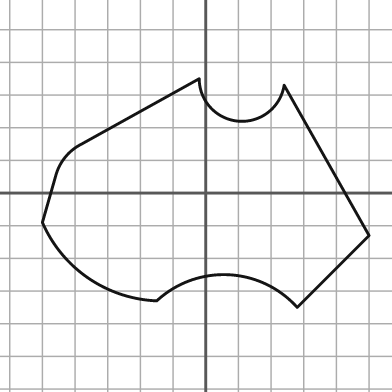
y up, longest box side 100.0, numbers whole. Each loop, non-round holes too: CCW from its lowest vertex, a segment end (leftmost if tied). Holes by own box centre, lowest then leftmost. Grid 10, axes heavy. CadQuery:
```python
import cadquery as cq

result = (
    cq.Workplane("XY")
    .moveTo(28.0, -35.0)
    .lineTo(50.0, -13.0)
    .lineTo(24.0, 33.0)
    .threePointArc((10.0, 22.0), (-2.0, 35.0))
    .lineTo(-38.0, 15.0)
    .threePointArc((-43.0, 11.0), (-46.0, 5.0))
    .lineTo(-50.0, -9.0)
    .threePointArc((-36.0, -26.0), (-15.0, -33.0))
    .threePointArc((7.0, -25.0), (28.0, -35.0))
    .close()
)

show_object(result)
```